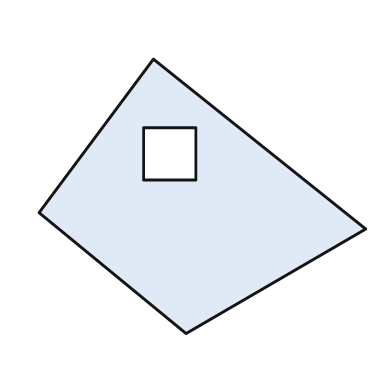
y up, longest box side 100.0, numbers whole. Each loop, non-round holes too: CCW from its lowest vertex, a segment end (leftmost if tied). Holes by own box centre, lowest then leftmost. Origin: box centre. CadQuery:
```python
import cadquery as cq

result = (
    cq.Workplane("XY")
    .moveTo(-5.0, -42.0)
    .lineTo(50.0, -10.0)
    .lineTo(-15.0, 42.0)
    .lineTo(-50.0, -5.0)
    .close()
    .moveTo(-18.0, 5.0)
    .lineTo(-2.0, 5.0)
    .lineTo(-2.0, 21.0)
    .lineTo(-18.0, 21.0)
    .close()
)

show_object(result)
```